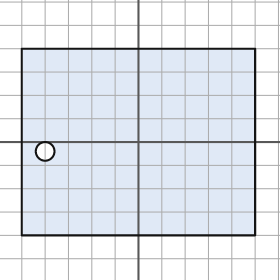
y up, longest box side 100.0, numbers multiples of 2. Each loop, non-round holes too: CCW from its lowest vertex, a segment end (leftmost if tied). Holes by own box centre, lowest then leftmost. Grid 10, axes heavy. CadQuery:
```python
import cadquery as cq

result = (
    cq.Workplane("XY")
    .moveTo(-50.0, -40.0)
    .lineTo(50.0, -40.0)
    .lineTo(50.0, 40.0)
    .lineTo(-50.0, 40.0)
    .close()
    .moveTo(-40.0, -4.0)
    .circle(4.0)
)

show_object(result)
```